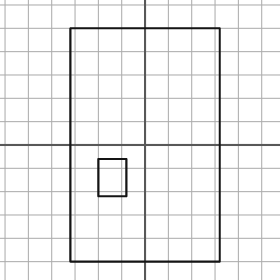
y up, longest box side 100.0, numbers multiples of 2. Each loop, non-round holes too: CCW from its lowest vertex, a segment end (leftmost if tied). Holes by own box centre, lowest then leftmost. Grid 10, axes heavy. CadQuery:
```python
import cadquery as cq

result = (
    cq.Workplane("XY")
    .moveTo(-32.0, -50.0)
    .lineTo(32.0, -50.0)
    .lineTo(32.0, 50.0)
    .lineTo(-32.0, 50.0)
    .close()
    .moveTo(-20.0, -22.0)
    .lineTo(-8.0, -22.0)
    .lineTo(-8.0, -6.0)
    .lineTo(-20.0, -6.0)
    .close()
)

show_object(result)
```